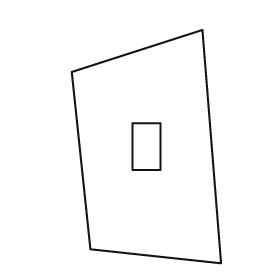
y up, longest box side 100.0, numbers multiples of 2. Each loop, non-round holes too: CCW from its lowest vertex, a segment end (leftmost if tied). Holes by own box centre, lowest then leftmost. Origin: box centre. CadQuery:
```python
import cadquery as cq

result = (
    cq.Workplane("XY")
    .moveTo(32.0, -50.0)
    .lineTo(24.0, 50.0)
    .lineTo(-32.0, 32.0)
    .lineTo(-24.0, -44.0)
    .close()
    .moveTo(-6.0, -10.0)
    .lineTo(6.0, -10.0)
    .lineTo(6.0, 10.0)
    .lineTo(-6.0, 10.0)
    .close()
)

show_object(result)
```